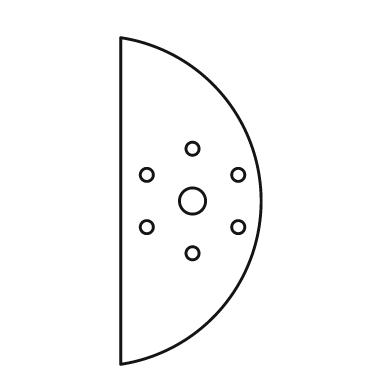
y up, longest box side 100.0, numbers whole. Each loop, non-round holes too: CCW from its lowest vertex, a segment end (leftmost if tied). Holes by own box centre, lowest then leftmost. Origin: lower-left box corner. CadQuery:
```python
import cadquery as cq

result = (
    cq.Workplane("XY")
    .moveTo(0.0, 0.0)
    .threePointArc((43.0, 50.0), (0.0, 100.0))
    .close()
    .moveTo(22.0, 34.0)
    .circle(2.0)
    .moveTo(8.0, 42.0)
    .circle(2.0)
    .moveTo(36.0, 42.0)
    .circle(2.0)
    .moveTo(22.0, 50.0)
    .circle(4.0)
    .moveTo(8.0, 58.0)
    .circle(2.0)
    .moveTo(36.0, 58.0)
    .circle(2.0)
    .moveTo(22.0, 66.0)
    .circle(2.0)
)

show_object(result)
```